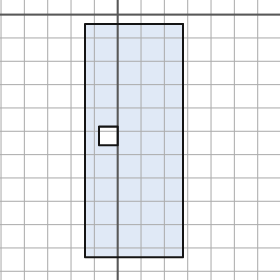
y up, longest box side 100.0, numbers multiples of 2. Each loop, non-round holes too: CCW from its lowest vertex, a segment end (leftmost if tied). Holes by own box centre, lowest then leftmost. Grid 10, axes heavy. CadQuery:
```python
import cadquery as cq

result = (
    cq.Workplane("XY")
    .moveTo(-14.0, -104.0)
    .lineTo(28.0, -104.0)
    .lineTo(28.0, -4.0)
    .lineTo(-14.0, -4.0)
    .close()
    .moveTo(-8.0, -56.0)
    .lineTo(0.0, -56.0)
    .lineTo(0.0, -48.0)
    .lineTo(-8.0, -48.0)
    .close()
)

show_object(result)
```